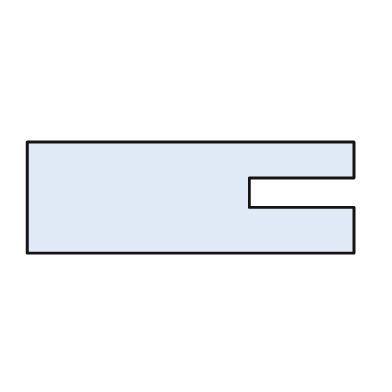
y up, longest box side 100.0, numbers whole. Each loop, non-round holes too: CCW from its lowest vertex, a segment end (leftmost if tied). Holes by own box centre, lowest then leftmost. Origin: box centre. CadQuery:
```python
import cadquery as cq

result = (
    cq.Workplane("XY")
    .moveTo(-50.0, -17.0)
    .lineTo(50.0, -17.0)
    .lineTo(50.0, -3.0)
    .lineTo(18.0, -3.0)
    .lineTo(18.0, 6.0)
    .lineTo(50.0, 6.0)
    .lineTo(50.0, 17.0)
    .lineTo(-50.0, 17.0)
    .close()
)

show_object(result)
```